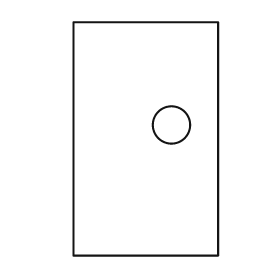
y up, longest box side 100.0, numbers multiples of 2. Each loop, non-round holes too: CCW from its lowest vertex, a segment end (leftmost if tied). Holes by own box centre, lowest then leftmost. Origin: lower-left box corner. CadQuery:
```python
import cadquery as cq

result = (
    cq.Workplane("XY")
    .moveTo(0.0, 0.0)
    .lineTo(62.0, 0.0)
    .lineTo(62.0, 100.0)
    .lineTo(0.0, 100.0)
    .close()
    .moveTo(42.0, 56.0)
    .circle(8.0)
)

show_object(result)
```